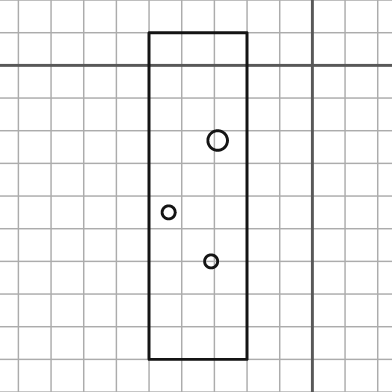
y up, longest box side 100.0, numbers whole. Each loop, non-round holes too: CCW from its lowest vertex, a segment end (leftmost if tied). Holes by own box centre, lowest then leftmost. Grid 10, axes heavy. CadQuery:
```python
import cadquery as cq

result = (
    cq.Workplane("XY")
    .moveTo(-50.0, -90.0)
    .lineTo(-20.0, -90.0)
    .lineTo(-20.0, 10.0)
    .lineTo(-50.0, 10.0)
    .close()
    .moveTo(-31.0, -60.0)
    .circle(2.0)
    .moveTo(-44.0, -45.0)
    .circle(2.0)
    .moveTo(-29.0, -23.0)
    .circle(3.0)
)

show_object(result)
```